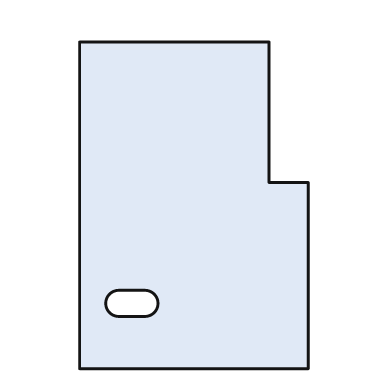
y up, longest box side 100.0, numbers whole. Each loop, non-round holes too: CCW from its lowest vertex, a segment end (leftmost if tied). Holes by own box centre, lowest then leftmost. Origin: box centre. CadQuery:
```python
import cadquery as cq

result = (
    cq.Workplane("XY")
    .moveTo(-35.0, -50.0)
    .lineTo(35.0, -50.0)
    .lineTo(35.0, 7.0)
    .lineTo(23.0, 7.0)
    .lineTo(23.0, 50.0)
    .lineTo(-35.0, 50.0)
    .close()
    .moveTo(-23.0, -34.0)
    .lineTo(-15.0, -34.0)
    .threePointArc((-11.0, -30.0), (-15.0, -26.0))
    .lineTo(-23.0, -26.0)
    .threePointArc((-27.0, -30.0), (-23.0, -34.0))
    .close()
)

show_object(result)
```